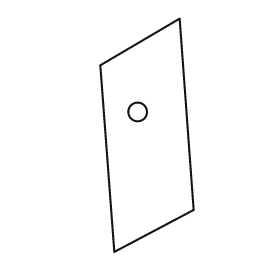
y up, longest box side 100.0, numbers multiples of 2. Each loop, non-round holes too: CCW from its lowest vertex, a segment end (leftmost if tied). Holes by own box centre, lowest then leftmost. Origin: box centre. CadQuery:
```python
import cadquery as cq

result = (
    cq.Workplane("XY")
    .moveTo(-14.0, -50.0)
    .lineTo(20.0, -32.0)
    .lineTo(14.0, 50.0)
    .lineTo(-20.0, 30.0)
    .close()
    .moveTo(-4.0, 10.0)
    .circle(4.0)
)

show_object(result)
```